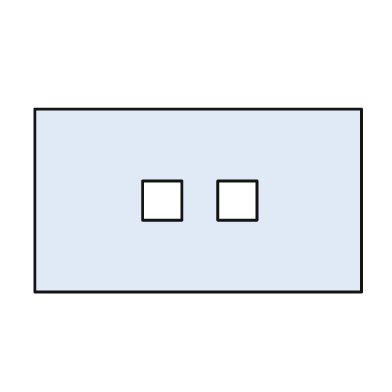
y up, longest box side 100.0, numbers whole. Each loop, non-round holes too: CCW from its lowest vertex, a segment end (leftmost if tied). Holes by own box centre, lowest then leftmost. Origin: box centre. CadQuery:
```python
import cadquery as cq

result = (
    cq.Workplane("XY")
    .moveTo(-50.0, -28.0)
    .lineTo(50.0, -28.0)
    .lineTo(50.0, 28.0)
    .lineTo(-50.0, 28.0)
    .close()
    .moveTo(-17.0, -6.0)
    .lineTo(-5.0, -6.0)
    .lineTo(-5.0, 6.0)
    .lineTo(-17.0, 6.0)
    .close()
    .moveTo(6.0, -6.0)
    .lineTo(18.0, -6.0)
    .lineTo(18.0, 6.0)
    .lineTo(6.0, 6.0)
    .close()
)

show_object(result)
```